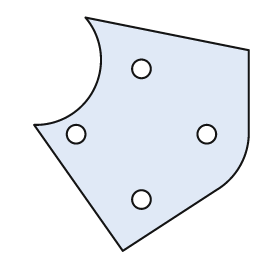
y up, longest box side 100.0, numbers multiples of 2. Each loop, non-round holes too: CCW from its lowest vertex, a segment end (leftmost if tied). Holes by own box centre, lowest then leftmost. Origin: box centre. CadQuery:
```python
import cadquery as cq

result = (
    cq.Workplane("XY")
    .moveTo(-8.0, -50.0)
    .lineTo(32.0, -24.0)
    .threePointArc((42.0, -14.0), (46.0, 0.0))
    .lineTo(46.0, 36.0)
    .lineTo(-24.0, 50.0)
    .threePointArc((-20.0, 20.0), (-46.0, 4.0))
    .close()
    .moveTo(0.0, -28.0)
    .circle(4.0)
    .moveTo(-28.0, 0.0)
    .circle(4.0)
    .moveTo(28.0, 0.0)
    .circle(4.0)
    .moveTo(0.0, 28.0)
    .circle(4.0)
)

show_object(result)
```